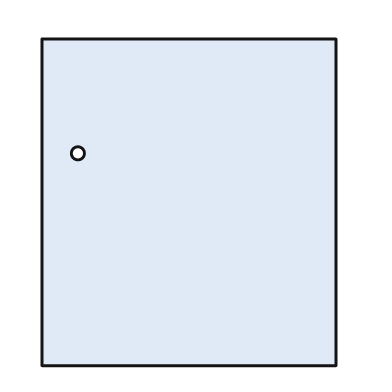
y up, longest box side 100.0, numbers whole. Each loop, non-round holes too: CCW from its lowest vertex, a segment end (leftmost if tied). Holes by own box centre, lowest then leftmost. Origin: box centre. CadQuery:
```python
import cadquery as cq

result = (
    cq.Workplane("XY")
    .moveTo(-45.0, -50.0)
    .lineTo(45.0, -50.0)
    .lineTo(45.0, 50.0)
    .lineTo(-45.0, 50.0)
    .close()
    .moveTo(-34.0, 15.0)
    .circle(2.0)
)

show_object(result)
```